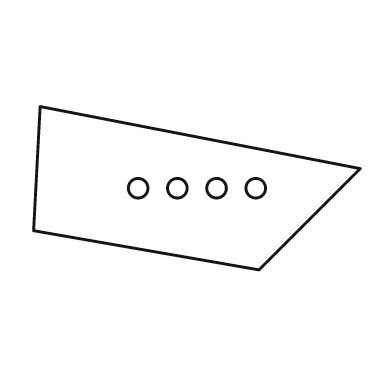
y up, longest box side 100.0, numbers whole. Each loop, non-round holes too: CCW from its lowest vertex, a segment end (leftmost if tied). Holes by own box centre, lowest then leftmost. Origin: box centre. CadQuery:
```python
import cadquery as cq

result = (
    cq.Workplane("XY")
    .moveTo(19.0, -25.0)
    .lineTo(50.0, 6.0)
    .lineTo(-48.0, 25.0)
    .lineTo(-50.0, -13.0)
    .close()
    .moveTo(-18.0, 0.0)
    .circle(3.0)
    .moveTo(-6.0, 0.0)
    .circle(3.0)
    .moveTo(6.0, 0.0)
    .circle(3.0)
    .moveTo(18.0, 0.0)
    .circle(3.0)
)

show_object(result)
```